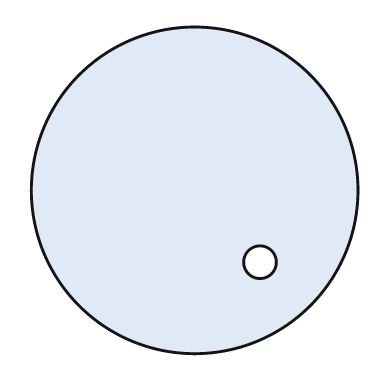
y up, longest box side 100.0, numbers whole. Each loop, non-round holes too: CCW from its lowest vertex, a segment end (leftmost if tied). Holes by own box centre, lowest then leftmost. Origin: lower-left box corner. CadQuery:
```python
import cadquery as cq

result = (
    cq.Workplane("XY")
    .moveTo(50.0, 50.0)
    .circle(50.0)
    .moveTo(70.0, 28.0)
    .circle(5.0)
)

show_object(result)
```